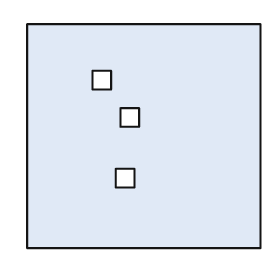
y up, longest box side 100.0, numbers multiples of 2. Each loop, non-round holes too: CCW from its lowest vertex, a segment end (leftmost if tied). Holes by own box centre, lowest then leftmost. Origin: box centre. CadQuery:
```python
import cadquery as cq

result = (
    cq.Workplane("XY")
    .moveTo(-50.0, -48.0)
    .lineTo(50.0, -48.0)
    .lineTo(50.0, 48.0)
    .lineTo(-50.0, 48.0)
    .close()
    .moveTo(-12.0, -22.0)
    .lineTo(-4.0, -22.0)
    .lineTo(-4.0, -14.0)
    .lineTo(-12.0, -14.0)
    .close()
    .moveTo(-10.0, 4.0)
    .lineTo(-2.0, 4.0)
    .lineTo(-2.0, 12.0)
    .lineTo(-10.0, 12.0)
    .close()
    .moveTo(-22.0, 20.0)
    .lineTo(-14.0, 20.0)
    .lineTo(-14.0, 28.0)
    .lineTo(-22.0, 28.0)
    .close()
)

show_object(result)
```